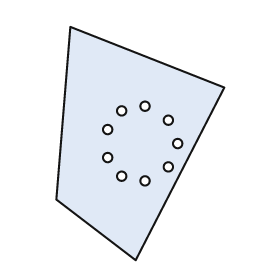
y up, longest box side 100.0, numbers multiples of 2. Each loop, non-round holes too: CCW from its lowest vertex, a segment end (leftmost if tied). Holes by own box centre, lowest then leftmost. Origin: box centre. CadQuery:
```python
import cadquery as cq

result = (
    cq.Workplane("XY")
    .moveTo(-2.0, -50.0)
    .lineTo(36.0, 24.0)
    .lineTo(-30.0, 50.0)
    .lineTo(-36.0, -24.0)
    .close()
    .moveTo(2.0, -16.0)
    .circle(2.0)
    .moveTo(-8.0, -14.0)
    .circle(2.0)
    .moveTo(12.0, -10.0)
    .circle(2.0)
    .moveTo(-14.0, -6.0)
    .circle(2.0)
    .moveTo(16.0, 0.0)
    .circle(2.0)
    .moveTo(-14.0, 6.0)
    .circle(2.0)
    .moveTo(12.0, 10.0)
    .circle(2.0)
    .moveTo(-8.0, 14.0)
    .circle(2.0)
    .moveTo(2.0, 16.0)
    .circle(2.0)
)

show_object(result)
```